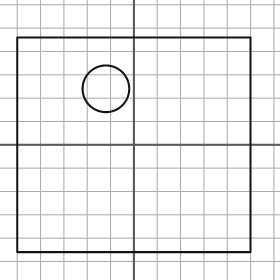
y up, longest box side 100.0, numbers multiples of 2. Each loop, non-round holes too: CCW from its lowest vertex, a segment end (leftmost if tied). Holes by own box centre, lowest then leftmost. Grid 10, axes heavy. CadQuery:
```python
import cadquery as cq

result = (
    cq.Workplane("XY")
    .moveTo(-50.0, -46.0)
    .lineTo(50.0, -46.0)
    .lineTo(50.0, 46.0)
    .lineTo(-50.0, 46.0)
    .close()
    .moveTo(-12.0, 24.0)
    .circle(10.0)
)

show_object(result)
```